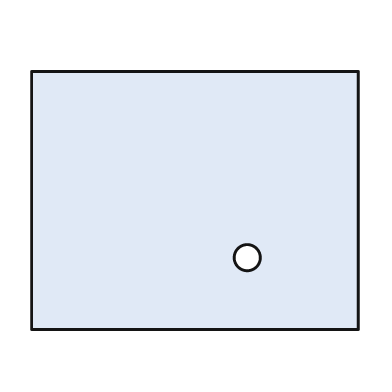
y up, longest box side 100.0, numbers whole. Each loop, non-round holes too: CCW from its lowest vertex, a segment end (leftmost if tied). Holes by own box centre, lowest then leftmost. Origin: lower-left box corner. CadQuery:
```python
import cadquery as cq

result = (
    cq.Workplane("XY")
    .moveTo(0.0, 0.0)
    .lineTo(100.0, 0.0)
    .lineTo(100.0, 79.0)
    .lineTo(0.0, 79.0)
    .close()
    .moveTo(66.0, 22.0)
    .circle(4.0)
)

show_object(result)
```